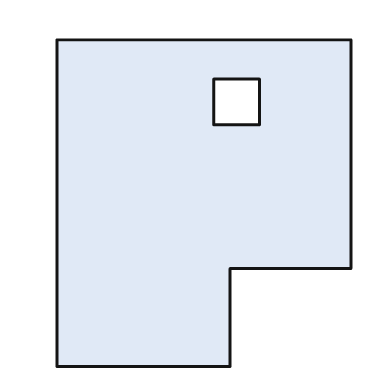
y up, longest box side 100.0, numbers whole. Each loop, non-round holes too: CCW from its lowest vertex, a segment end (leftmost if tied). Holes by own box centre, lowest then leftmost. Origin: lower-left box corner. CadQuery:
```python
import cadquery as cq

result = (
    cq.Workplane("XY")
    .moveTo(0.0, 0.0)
    .lineTo(53.0, 0.0)
    .lineTo(53.0, 30.0)
    .lineTo(90.0, 30.0)
    .lineTo(90.0, 100.0)
    .lineTo(0.0, 100.0)
    .close()
    .moveTo(48.0, 74.0)
    .lineTo(62.0, 74.0)
    .lineTo(62.0, 88.0)
    .lineTo(48.0, 88.0)
    .close()
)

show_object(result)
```